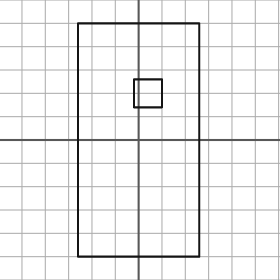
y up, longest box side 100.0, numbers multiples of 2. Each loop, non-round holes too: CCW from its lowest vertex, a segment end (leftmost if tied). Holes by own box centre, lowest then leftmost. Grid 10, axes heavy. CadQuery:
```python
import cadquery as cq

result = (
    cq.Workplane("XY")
    .moveTo(-26.0, -50.0)
    .lineTo(26.0, -50.0)
    .lineTo(26.0, 50.0)
    .lineTo(-26.0, 50.0)
    .close()
    .moveTo(-2.0, 14.0)
    .lineTo(10.0, 14.0)
    .lineTo(10.0, 26.0)
    .lineTo(-2.0, 26.0)
    .close()
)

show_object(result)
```